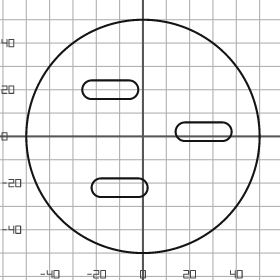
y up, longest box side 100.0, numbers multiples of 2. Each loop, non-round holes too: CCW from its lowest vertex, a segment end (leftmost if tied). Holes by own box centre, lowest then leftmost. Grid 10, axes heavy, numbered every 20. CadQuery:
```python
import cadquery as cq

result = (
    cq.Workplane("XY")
    .moveTo(0.0, 0.0)
    .circle(50.0)
    .moveTo(-18.0, -26.0)
    .lineTo(-2.0, -26.0)
    .threePointArc((2.0, -22.0), (-2.0, -18.0))
    .lineTo(-18.0, -18.0)
    .threePointArc((-22.0, -22.0), (-18.0, -26.0))
    .close()
    .moveTo(18.0, -2.0)
    .lineTo(34.0, -2.0)
    .threePointArc((38.0, 2.0), (34.0, 6.0))
    .lineTo(18.0, 6.0)
    .threePointArc((14.0, 2.0), (18.0, -2.0))
    .close()
    .moveTo(-22.0, 16.0)
    .lineTo(-6.0, 16.0)
    .threePointArc((-2.0, 20.0), (-6.0, 24.0))
    .lineTo(-22.0, 24.0)
    .threePointArc((-26.0, 20.0), (-22.0, 16.0))
    .close()
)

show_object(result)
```